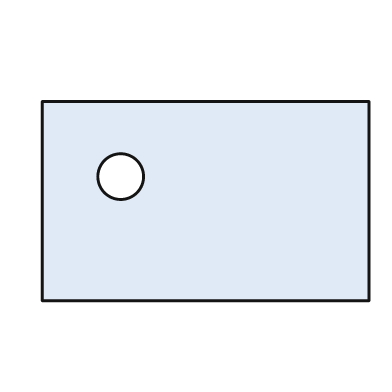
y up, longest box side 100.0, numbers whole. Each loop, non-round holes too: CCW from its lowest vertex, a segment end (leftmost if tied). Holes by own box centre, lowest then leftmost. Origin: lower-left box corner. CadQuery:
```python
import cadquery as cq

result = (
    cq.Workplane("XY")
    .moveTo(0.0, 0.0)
    .lineTo(100.0, 0.0)
    .lineTo(100.0, 61.0)
    .lineTo(0.0, 61.0)
    .close()
    .moveTo(24.0, 38.0)
    .circle(7.0)
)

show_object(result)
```